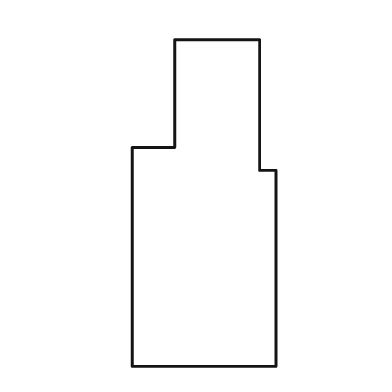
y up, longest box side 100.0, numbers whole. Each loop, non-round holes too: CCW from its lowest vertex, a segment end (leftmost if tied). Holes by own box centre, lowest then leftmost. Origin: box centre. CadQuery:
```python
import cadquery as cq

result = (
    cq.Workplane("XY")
    .moveTo(-22.0, -50.0)
    .lineTo(22.0, -50.0)
    .lineTo(22.0, 10.0)
    .lineTo(17.0, 10.0)
    .lineTo(17.0, 50.0)
    .lineTo(-9.0, 50.0)
    .lineTo(-9.0, 17.0)
    .lineTo(-22.0, 17.0)
    .close()
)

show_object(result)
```